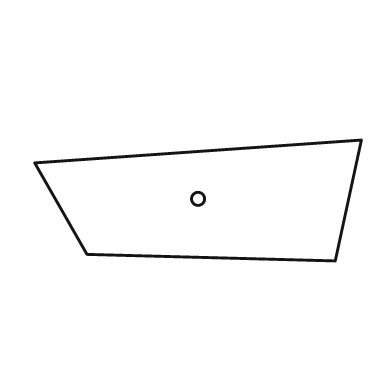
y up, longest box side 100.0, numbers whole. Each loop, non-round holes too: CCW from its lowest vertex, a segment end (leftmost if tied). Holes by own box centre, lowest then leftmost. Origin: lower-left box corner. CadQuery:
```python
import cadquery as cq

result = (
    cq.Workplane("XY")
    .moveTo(92.0, 0.0)
    .lineTo(100.0, 37.0)
    .lineTo(0.0, 30.0)
    .lineTo(16.0, 2.0)
    .close()
    .moveTo(50.0, 19.0)
    .circle(2.0)
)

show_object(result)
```